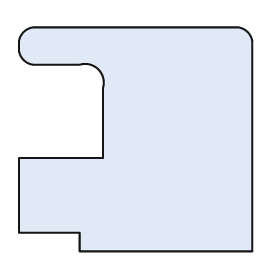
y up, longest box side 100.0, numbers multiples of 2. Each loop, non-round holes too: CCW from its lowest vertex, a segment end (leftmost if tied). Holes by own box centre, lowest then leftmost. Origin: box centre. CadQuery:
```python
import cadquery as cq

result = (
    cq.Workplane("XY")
    .moveTo(-24.0, -48.0)
    .lineTo(50.0, -48.0)
    .lineTo(50.0, 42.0)
    .threePointArc((48.0, 46.0), (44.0, 48.0))
    .lineTo(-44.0, 48.0)
    .threePointArc((-48.0, 46.0), (-50.0, 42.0))
    .lineTo(-50.0, 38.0)
    .threePointArc((-48.0, 34.0), (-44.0, 32.0))
    .lineTo(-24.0, 32.0)
    .threePointArc((-16.0, 30.0), (-14.0, 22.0))
    .lineTo(-14.0, -8.0)
    .lineTo(-50.0, -8.0)
    .lineTo(-50.0, -40.0)
    .lineTo(-24.0, -40.0)
    .close()
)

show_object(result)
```